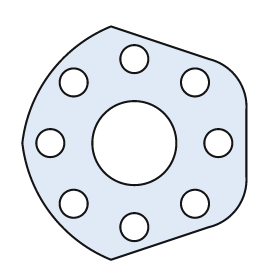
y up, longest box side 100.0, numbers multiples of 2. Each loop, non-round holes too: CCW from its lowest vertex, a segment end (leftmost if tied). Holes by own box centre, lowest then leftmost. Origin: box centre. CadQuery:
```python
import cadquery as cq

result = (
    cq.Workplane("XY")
    .moveTo(-10.0, -50.0)
    .lineTo(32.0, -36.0)
    .threePointArc((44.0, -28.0), (48.0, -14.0))
    .lineTo(48.0, 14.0)
    .threePointArc((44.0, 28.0), (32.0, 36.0))
    .lineTo(-10.0, 50.0)
    .threePointArc((-36.0, 30.0), (-48.0, 0.0))
    .threePointArc((-36.0, -30.0), (-10.0, -50.0))
    .close()
    .moveTo(0.0, -36.0)
    .circle(6.0)
    .moveTo(-26.0, -26.0)
    .circle(6.0)
    .moveTo(26.0, -26.0)
    .circle(6.0)
    .moveTo(-36.0, 0.0)
    .circle(6.0)
    .moveTo(0.0, 0.0)
    .circle(18.0)
    .moveTo(36.0, 0.0)
    .circle(6.0)
    .moveTo(-26.0, 26.0)
    .circle(6.0)
    .moveTo(26.0, 26.0)
    .circle(6.0)
    .moveTo(0.0, 36.0)
    .circle(6.0)
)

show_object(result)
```